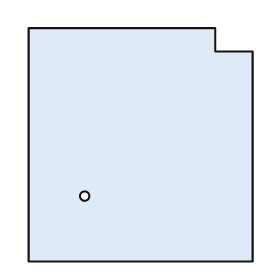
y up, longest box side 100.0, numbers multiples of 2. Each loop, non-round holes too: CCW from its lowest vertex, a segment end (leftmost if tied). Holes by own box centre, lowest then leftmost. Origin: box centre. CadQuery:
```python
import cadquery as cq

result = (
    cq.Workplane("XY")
    .moveTo(-48.0, -50.0)
    .lineTo(48.0, -50.0)
    .lineTo(48.0, 40.0)
    .lineTo(32.0, 40.0)
    .lineTo(32.0, 50.0)
    .lineTo(-48.0, 50.0)
    .close()
    .moveTo(-24.0, -22.0)
    .circle(2.0)
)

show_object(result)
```